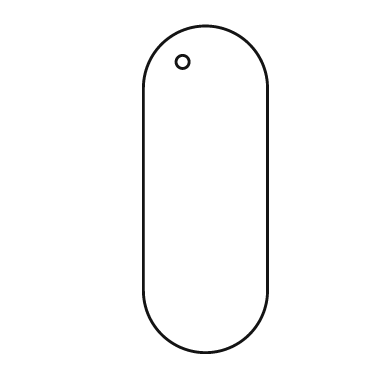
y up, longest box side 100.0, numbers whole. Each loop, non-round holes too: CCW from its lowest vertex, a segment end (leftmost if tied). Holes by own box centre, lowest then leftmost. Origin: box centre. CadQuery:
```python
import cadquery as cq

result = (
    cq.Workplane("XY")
    .moveTo(-19.0, -31.0)
    .threePointArc((0.0, -50.0), (19.0, -31.0))
    .lineTo(19.0, 31.0)
    .threePointArc((0.0, 50.0), (-19.0, 31.0))
    .close()
    .moveTo(-7.0, 39.0)
    .circle(2.0)
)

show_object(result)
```